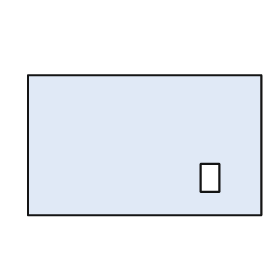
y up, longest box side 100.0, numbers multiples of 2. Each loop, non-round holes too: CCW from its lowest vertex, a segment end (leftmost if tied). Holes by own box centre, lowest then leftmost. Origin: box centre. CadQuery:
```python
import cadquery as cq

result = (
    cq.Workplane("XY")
    .moveTo(-50.0, -30.0)
    .lineTo(50.0, -30.0)
    .lineTo(50.0, 30.0)
    .lineTo(-50.0, 30.0)
    .close()
    .moveTo(24.0, -20.0)
    .lineTo(32.0, -20.0)
    .lineTo(32.0, -8.0)
    .lineTo(24.0, -8.0)
    .close()
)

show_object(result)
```